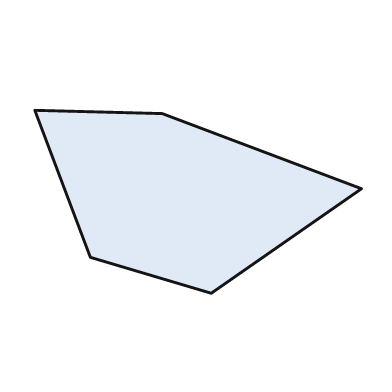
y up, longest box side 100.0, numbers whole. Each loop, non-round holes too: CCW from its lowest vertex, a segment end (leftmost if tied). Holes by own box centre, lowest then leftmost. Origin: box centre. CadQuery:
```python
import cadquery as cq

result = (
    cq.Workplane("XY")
    .moveTo(4.0, -28.0)
    .lineTo(50.0, 4.0)
    .lineTo(-11.0, 27.0)
    .lineTo(-50.0, 28.0)
    .lineTo(-33.0, -17.0)
    .close()
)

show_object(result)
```